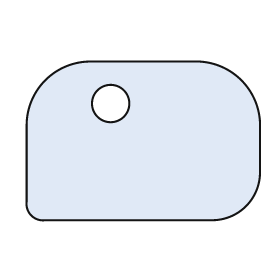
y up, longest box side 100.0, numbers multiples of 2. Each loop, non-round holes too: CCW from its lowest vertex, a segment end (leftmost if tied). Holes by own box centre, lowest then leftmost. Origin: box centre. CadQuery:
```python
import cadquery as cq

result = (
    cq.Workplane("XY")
    .moveTo(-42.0, -34.0)
    .lineTo(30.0, -34.0)
    .threePointArc((44.0, -28.0), (50.0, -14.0))
    .lineTo(50.0, 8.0)
    .threePointArc((42.0, 26.0), (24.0, 34.0))
    .lineTo(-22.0, 34.0)
    .threePointArc((-42.0, 26.0), (-50.0, 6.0))
    .lineTo(-50.0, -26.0)
    .threePointArc((-48.0, -32.0), (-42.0, -34.0))
    .close()
    .moveTo(-14.0, 16.0)
    .circle(8.0)
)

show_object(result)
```